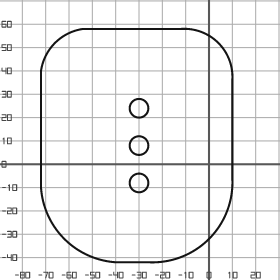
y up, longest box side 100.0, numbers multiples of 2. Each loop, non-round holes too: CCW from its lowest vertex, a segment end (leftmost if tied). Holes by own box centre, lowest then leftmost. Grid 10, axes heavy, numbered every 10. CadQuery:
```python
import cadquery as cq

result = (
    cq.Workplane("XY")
    .moveTo(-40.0, -42.0)
    .lineTo(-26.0, -42.0)
    .threePointArc((0.0, -32.0), (10.0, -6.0))
    .lineTo(10.0, 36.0)
    .threePointArc((4.0, 52.0), (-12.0, 58.0))
    .lineTo(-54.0, 58.0)
    .threePointArc((-66.0, 52.0), (-72.0, 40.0))
    .lineTo(-72.0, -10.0)
    .threePointArc((-62.0, -32.0), (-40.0, -42.0))
    .close()
    .moveTo(-30.0, -8.0)
    .circle(4.0)
    .moveTo(-30.0, 8.0)
    .circle(4.0)
    .moveTo(-30.0, 24.0)
    .circle(4.0)
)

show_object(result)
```